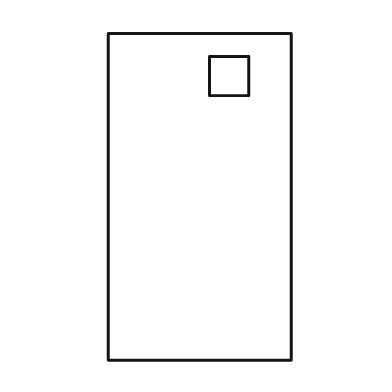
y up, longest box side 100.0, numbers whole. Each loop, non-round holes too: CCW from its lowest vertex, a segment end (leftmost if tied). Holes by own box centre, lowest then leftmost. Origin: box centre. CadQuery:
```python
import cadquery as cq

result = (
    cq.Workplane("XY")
    .moveTo(-28.0, -50.0)
    .lineTo(28.0, -50.0)
    .lineTo(28.0, 50.0)
    .lineTo(-28.0, 50.0)
    .close()
    .moveTo(3.0, 31.0)
    .lineTo(15.0, 31.0)
    .lineTo(15.0, 43.0)
    .lineTo(3.0, 43.0)
    .close()
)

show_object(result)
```